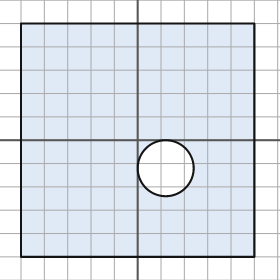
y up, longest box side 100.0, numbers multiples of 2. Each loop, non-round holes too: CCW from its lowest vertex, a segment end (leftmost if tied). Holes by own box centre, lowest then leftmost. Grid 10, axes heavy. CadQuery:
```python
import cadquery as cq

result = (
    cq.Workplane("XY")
    .moveTo(-50.0, -50.0)
    .lineTo(50.0, -50.0)
    .lineTo(50.0, 50.0)
    .lineTo(-50.0, 50.0)
    .close()
    .moveTo(12.0, -12.0)
    .circle(12.0)
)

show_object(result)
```